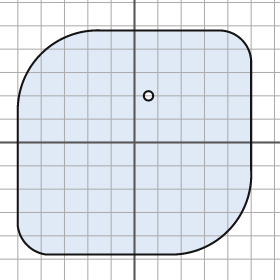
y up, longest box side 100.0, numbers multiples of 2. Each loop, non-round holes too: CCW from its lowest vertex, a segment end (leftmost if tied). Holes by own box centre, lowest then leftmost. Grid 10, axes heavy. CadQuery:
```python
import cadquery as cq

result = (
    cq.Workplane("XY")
    .moveTo(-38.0, -48.0)
    .lineTo(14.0, -48.0)
    .threePointArc((40.0, -38.0), (50.0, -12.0))
    .lineTo(50.0, 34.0)
    .threePointArc((46.0, 44.0), (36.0, 48.0))
    .lineTo(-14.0, 48.0)
    .threePointArc((-40.0, 38.0), (-50.0, 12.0))
    .lineTo(-50.0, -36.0)
    .threePointArc((-46.0, -44.0), (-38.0, -48.0))
    .close()
    .moveTo(6.0, 20.0)
    .circle(2.0)
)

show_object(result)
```